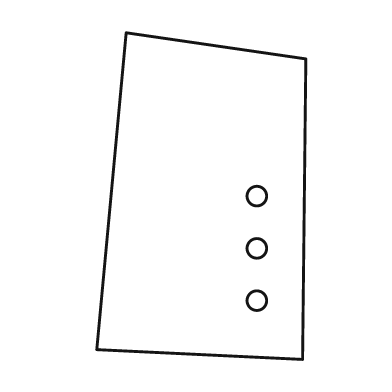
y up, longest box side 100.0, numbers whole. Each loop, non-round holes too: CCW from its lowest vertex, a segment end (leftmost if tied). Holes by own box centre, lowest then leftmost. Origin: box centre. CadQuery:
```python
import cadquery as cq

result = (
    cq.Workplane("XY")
    .moveTo(31.0, -50.0)
    .lineTo(32.0, 42.0)
    .lineTo(-23.0, 50.0)
    .lineTo(-32.0, -47.0)
    .close()
    .moveTo(17.0, -32.0)
    .circle(3.0)
    .moveTo(17.0, -16.0)
    .circle(3.0)
    .moveTo(17.0, 0.0)
    .circle(3.0)
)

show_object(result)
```